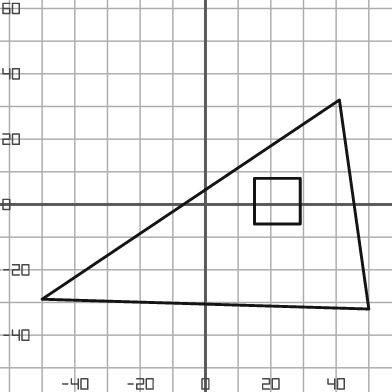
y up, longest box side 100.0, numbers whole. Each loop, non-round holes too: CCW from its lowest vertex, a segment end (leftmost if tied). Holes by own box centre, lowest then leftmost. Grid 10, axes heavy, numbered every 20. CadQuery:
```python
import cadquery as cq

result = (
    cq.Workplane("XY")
    .moveTo(50.0, -32.0)
    .lineTo(41.0, 32.0)
    .lineTo(-50.0, -29.0)
    .close()
    .moveTo(15.0, -6.0)
    .lineTo(29.0, -6.0)
    .lineTo(29.0, 8.0)
    .lineTo(15.0, 8.0)
    .close()
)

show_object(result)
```